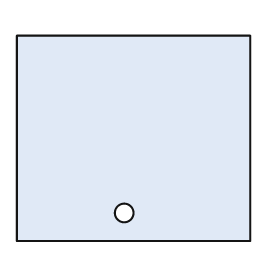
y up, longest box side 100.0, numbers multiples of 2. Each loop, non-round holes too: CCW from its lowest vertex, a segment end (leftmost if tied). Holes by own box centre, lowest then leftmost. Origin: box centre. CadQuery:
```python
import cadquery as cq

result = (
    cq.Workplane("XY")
    .moveTo(-50.0, -44.0)
    .lineTo(50.0, -44.0)
    .lineTo(50.0, 44.0)
    .lineTo(-50.0, 44.0)
    .close()
    .moveTo(-4.0, -32.0)
    .circle(4.0)
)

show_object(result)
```